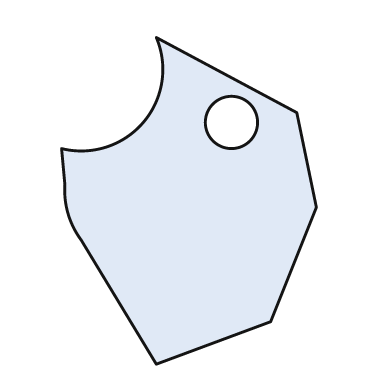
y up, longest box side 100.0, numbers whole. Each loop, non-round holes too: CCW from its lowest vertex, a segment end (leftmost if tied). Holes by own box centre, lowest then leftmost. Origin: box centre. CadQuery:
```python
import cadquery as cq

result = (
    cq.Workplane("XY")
    .moveTo(-10.0, -50.0)
    .lineTo(25.0, -37.0)
    .lineTo(39.0, -2.0)
    .lineTo(33.0, 27.0)
    .lineTo(-10.0, 50.0)
    .threePointArc((-14.0, 24.0), (-39.0, 16.0))
    .lineTo(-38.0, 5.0)
    .threePointArc((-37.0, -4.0), (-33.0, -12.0))
    .close()
    .moveTo(13.0, 24.0)
    .circle(8.0)
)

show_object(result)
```